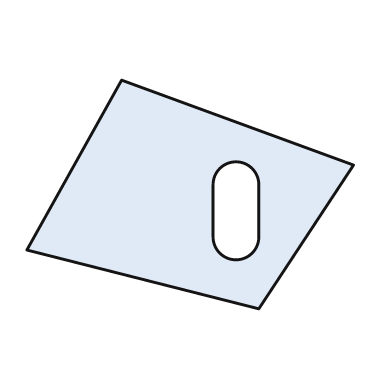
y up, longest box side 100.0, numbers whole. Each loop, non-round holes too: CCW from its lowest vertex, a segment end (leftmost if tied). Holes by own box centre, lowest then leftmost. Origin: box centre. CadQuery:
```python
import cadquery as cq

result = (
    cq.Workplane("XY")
    .moveTo(21.0, -35.0)
    .lineTo(50.0, 9.0)
    .lineTo(-21.0, 35.0)
    .lineTo(-50.0, -17.0)
    .close()
    .moveTo(7.0, -13.0)
    .threePointArc((14.0, -20.0), (21.0, -13.0))
    .lineTo(21.0, 3.0)
    .threePointArc((14.0, 10.0), (7.0, 3.0))
    .close()
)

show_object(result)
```